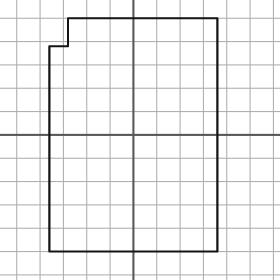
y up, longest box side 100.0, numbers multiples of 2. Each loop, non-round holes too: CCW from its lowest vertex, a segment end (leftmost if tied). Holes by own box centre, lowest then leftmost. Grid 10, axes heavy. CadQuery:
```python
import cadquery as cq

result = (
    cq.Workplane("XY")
    .moveTo(-36.0, -50.0)
    .lineTo(36.0, -50.0)
    .lineTo(36.0, 50.0)
    .lineTo(-28.0, 50.0)
    .lineTo(-28.0, 38.0)
    .lineTo(-36.0, 38.0)
    .close()
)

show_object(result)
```